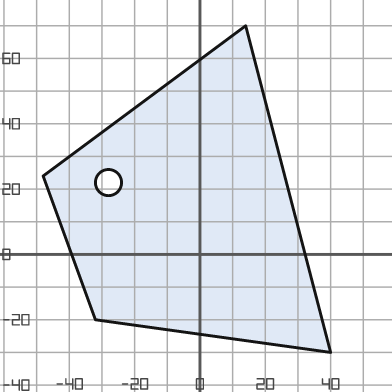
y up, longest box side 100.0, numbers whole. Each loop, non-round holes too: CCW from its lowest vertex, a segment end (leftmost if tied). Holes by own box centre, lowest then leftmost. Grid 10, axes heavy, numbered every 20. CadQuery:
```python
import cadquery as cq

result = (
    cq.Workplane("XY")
    .moveTo(40.0, -30.0)
    .lineTo(14.0, 70.0)
    .lineTo(-48.0, 24.0)
    .lineTo(-32.0, -20.0)
    .close()
    .moveTo(-28.0, 22.0)
    .circle(4.0)
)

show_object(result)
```